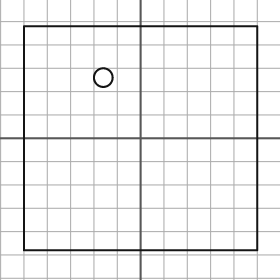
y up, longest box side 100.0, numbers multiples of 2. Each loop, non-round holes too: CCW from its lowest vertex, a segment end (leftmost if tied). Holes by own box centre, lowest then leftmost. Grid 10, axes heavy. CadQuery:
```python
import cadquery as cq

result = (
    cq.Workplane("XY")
    .moveTo(-50.0, -48.0)
    .lineTo(50.0, -48.0)
    .lineTo(50.0, 48.0)
    .lineTo(-50.0, 48.0)
    .close()
    .moveTo(-16.0, 26.0)
    .circle(4.0)
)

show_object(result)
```